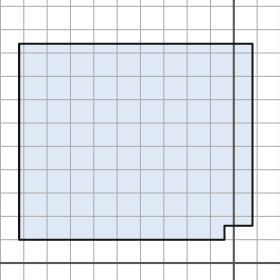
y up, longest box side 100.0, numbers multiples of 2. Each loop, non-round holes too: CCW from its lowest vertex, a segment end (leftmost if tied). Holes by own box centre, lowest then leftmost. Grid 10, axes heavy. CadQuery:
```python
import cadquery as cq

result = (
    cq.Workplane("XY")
    .moveTo(-92.0, 10.0)
    .lineTo(-4.0, 10.0)
    .lineTo(-4.0, 16.0)
    .lineTo(8.0, 16.0)
    .lineTo(8.0, 94.0)
    .lineTo(-92.0, 94.0)
    .close()
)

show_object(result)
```